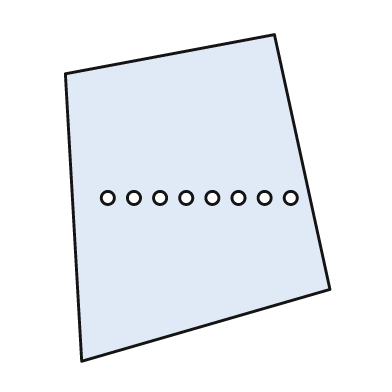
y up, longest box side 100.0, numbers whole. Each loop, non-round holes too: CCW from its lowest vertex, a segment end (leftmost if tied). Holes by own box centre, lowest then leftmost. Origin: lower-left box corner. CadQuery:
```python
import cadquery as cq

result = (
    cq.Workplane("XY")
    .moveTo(5.0, 0.0)
    .lineTo(81.0, 22.0)
    .lineTo(64.0, 100.0)
    .lineTo(0.0, 88.0)
    .close()
    .moveTo(13.0, 50.0)
    .circle(2.0)
    .moveTo(21.0, 50.0)
    .circle(2.0)
    .moveTo(29.0, 50.0)
    .circle(2.0)
    .moveTo(37.0, 50.0)
    .circle(2.0)
    .moveTo(45.0, 50.0)
    .circle(2.0)
    .moveTo(53.0, 50.0)
    .circle(2.0)
    .moveTo(61.0, 50.0)
    .circle(2.0)
    .moveTo(69.0, 50.0)
    .circle(2.0)
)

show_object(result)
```